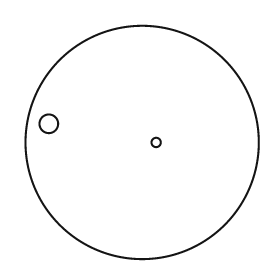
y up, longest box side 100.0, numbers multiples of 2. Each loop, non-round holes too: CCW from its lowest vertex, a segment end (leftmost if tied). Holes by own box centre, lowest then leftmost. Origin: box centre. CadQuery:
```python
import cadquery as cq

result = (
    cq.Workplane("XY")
    .moveTo(0.0, 0.0)
    .circle(50.0)
    .moveTo(6.0, 0.0)
    .circle(2.0)
    .moveTo(-40.0, 8.0)
    .circle(4.0)
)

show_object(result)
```